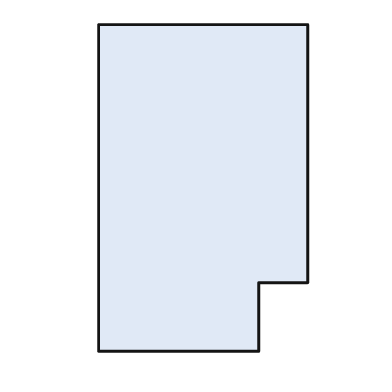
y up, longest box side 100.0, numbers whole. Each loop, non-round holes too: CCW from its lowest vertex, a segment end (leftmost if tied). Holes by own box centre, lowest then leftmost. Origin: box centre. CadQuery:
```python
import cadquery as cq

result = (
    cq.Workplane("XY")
    .moveTo(-32.0, -50.0)
    .lineTo(17.0, -50.0)
    .lineTo(17.0, -29.0)
    .lineTo(32.0, -29.0)
    .lineTo(32.0, 50.0)
    .lineTo(-32.0, 50.0)
    .close()
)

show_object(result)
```